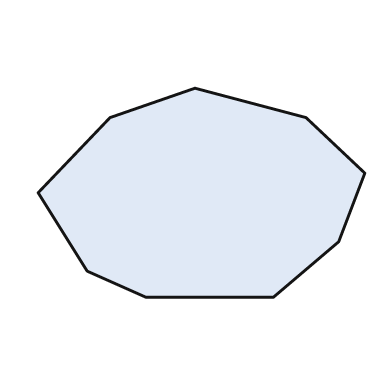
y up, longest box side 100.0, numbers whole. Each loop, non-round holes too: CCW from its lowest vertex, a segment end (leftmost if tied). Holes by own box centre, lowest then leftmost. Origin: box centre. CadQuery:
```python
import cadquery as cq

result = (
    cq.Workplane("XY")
    .moveTo(-17.0, -32.0)
    .lineTo(22.0, -32.0)
    .lineTo(42.0, -15.0)
    .lineTo(50.0, 6.0)
    .lineTo(32.0, 23.0)
    .lineTo(-2.0, 32.0)
    .lineTo(-28.0, 23.0)
    .lineTo(-50.0, 0.0)
    .lineTo(-35.0, -24.0)
    .close()
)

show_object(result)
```